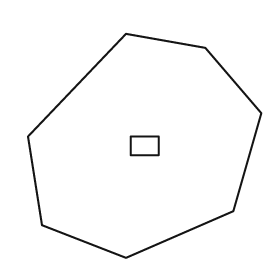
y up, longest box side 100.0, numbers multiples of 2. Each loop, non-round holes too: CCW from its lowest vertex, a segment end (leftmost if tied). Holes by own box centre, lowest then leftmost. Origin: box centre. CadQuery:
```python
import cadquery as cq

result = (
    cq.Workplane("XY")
    .moveTo(-8.0, -48.0)
    .lineTo(38.0, -28.0)
    .lineTo(50.0, 14.0)
    .lineTo(26.0, 42.0)
    .lineTo(-8.0, 48.0)
    .lineTo(-50.0, 4.0)
    .lineTo(-44.0, -34.0)
    .close()
    .moveTo(-6.0, -4.0)
    .lineTo(6.0, -4.0)
    .lineTo(6.0, 4.0)
    .lineTo(-6.0, 4.0)
    .close()
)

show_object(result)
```